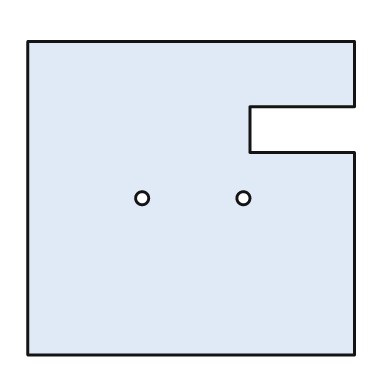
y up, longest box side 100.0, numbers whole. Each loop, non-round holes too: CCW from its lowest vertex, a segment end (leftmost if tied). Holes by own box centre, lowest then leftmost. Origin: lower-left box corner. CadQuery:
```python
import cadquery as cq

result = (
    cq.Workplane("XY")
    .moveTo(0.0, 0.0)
    .lineTo(100.0, 0.0)
    .lineTo(100.0, 62.0)
    .lineTo(68.0, 62.0)
    .lineTo(68.0, 76.0)
    .lineTo(100.0, 76.0)
    .lineTo(100.0, 96.0)
    .lineTo(0.0, 96.0)
    .close()
    .moveTo(35.0, 48.0)
    .circle(2.0)
    .moveTo(66.0, 48.0)
    .circle(2.0)
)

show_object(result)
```